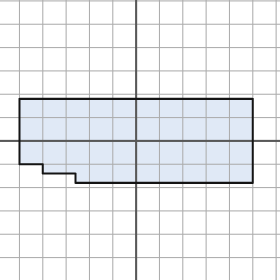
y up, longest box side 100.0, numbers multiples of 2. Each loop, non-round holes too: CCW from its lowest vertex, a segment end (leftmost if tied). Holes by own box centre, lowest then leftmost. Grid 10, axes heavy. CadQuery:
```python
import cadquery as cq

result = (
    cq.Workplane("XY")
    .moveTo(-26.0, -18.0)
    .lineTo(50.0, -18.0)
    .lineTo(50.0, 18.0)
    .lineTo(-50.0, 18.0)
    .lineTo(-50.0, -10.0)
    .lineTo(-40.0, -10.0)
    .lineTo(-40.0, -14.0)
    .lineTo(-26.0, -14.0)
    .close()
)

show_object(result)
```